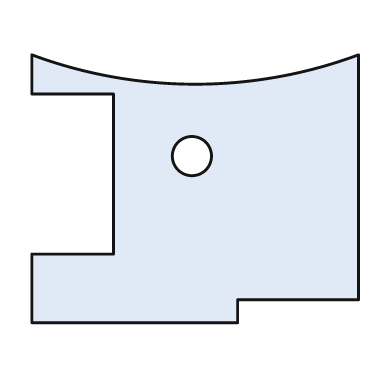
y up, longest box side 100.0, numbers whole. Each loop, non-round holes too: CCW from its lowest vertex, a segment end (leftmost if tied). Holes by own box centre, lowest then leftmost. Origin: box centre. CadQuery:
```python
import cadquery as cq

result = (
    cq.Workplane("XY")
    .moveTo(-50.0, -41.0)
    .lineTo(13.0, -41.0)
    .lineTo(13.0, -34.0)
    .lineTo(50.0, -34.0)
    .lineTo(50.0, 41.0)
    .threePointArc((0.0, 32.0), (-50.0, 41.0))
    .lineTo(-50.0, 29.0)
    .lineTo(-25.0, 29.0)
    .lineTo(-25.0, -20.0)
    .lineTo(-50.0, -20.0)
    .close()
    .moveTo(-1.0, 10.0)
    .circle(6.0)
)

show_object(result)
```